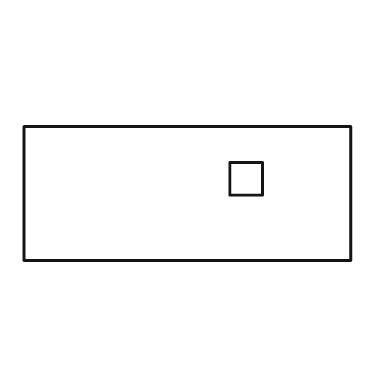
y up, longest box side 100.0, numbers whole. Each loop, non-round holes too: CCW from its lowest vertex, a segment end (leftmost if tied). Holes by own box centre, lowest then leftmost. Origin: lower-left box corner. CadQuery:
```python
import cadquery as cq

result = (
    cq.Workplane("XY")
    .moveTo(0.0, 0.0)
    .lineTo(100.0, 0.0)
    .lineTo(100.0, 41.0)
    .lineTo(0.0, 41.0)
    .close()
    .moveTo(63.0, 20.0)
    .lineTo(73.0, 20.0)
    .lineTo(73.0, 30.0)
    .lineTo(63.0, 30.0)
    .close()
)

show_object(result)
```